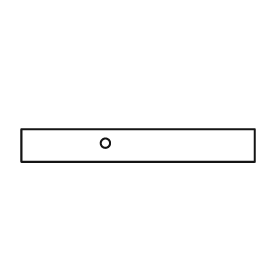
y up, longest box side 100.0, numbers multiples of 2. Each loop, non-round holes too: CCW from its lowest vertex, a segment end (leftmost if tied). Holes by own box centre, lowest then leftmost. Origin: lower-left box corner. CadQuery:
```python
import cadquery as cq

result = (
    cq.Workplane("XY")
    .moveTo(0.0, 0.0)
    .lineTo(100.0, 0.0)
    .lineTo(100.0, 14.0)
    .lineTo(0.0, 14.0)
    .close()
    .moveTo(36.0, 8.0)
    .circle(2.0)
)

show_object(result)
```